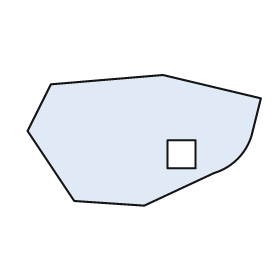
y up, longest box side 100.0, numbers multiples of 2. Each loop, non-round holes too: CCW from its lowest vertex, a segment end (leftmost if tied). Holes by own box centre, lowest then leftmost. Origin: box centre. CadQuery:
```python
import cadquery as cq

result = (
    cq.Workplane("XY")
    .moveTo(0.0, -28.0)
    .lineTo(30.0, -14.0)
    .threePointArc((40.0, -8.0), (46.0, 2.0))
    .lineTo(50.0, 18.0)
    .lineTo(8.0, 28.0)
    .lineTo(-40.0, 24.0)
    .lineTo(-50.0, 4.0)
    .lineTo(-30.0, -26.0)
    .close()
    .moveTo(10.0, -12.0)
    .lineTo(22.0, -12.0)
    .lineTo(22.0, 0.0)
    .lineTo(10.0, 0.0)
    .close()
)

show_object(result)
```